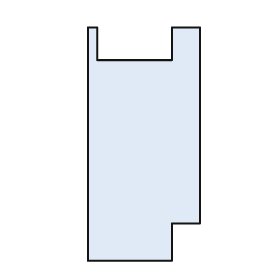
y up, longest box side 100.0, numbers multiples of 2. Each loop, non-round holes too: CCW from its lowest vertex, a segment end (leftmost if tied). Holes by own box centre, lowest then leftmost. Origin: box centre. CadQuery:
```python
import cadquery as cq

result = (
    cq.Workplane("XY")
    .moveTo(-24.0, -50.0)
    .lineTo(12.0, -50.0)
    .lineTo(12.0, -34.0)
    .lineTo(24.0, -34.0)
    .lineTo(24.0, 50.0)
    .lineTo(12.0, 50.0)
    .lineTo(12.0, 36.0)
    .lineTo(-20.0, 36.0)
    .lineTo(-20.0, 50.0)
    .lineTo(-24.0, 50.0)
    .close()
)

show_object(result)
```